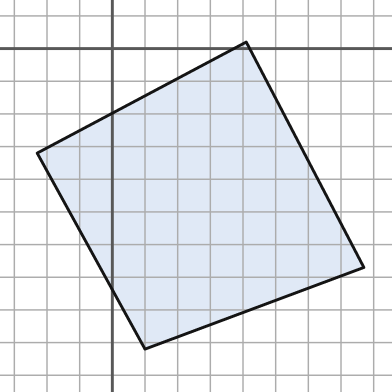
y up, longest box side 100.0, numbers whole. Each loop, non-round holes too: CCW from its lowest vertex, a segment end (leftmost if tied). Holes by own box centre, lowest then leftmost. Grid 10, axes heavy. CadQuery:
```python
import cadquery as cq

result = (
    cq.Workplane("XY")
    .moveTo(10.0, -92.0)
    .lineTo(77.0, -67.0)
    .lineTo(41.0, 2.0)
    .lineTo(-23.0, -32.0)
    .close()
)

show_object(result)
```